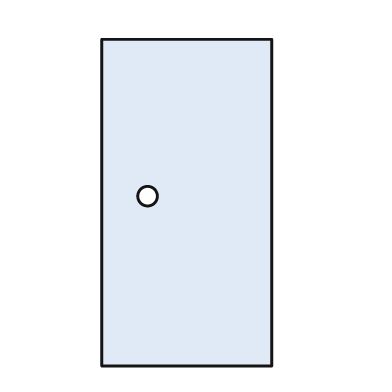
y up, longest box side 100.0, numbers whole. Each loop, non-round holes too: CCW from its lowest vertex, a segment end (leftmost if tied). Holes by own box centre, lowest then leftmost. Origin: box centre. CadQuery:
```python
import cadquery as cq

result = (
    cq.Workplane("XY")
    .moveTo(-26.0, -50.0)
    .lineTo(26.0, -50.0)
    .lineTo(26.0, 50.0)
    .lineTo(-26.0, 50.0)
    .close()
    .moveTo(-12.0, 2.0)
    .circle(3.0)
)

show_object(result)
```